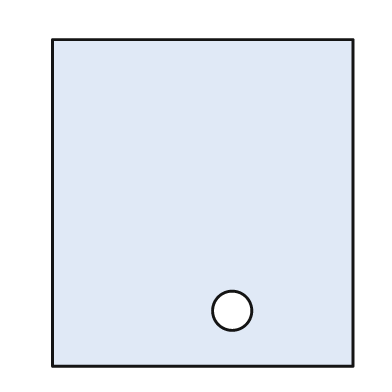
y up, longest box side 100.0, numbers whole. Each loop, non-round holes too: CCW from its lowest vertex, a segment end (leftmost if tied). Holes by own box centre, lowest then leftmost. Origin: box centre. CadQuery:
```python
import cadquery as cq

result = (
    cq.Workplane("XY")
    .moveTo(-46.0, -50.0)
    .lineTo(46.0, -50.0)
    .lineTo(46.0, 50.0)
    .lineTo(-46.0, 50.0)
    .close()
    .moveTo(9.0, -33.0)
    .circle(6.0)
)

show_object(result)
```